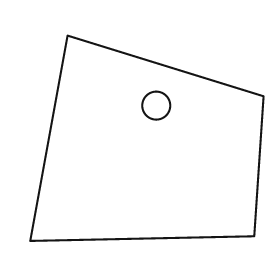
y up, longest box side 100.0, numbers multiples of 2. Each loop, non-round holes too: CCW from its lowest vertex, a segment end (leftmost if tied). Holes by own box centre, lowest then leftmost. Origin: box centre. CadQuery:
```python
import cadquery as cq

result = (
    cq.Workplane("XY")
    .moveTo(-50.0, -44.0)
    .lineTo(46.0, -42.0)
    .lineTo(50.0, 18.0)
    .lineTo(-34.0, 44.0)
    .close()
    .moveTo(4.0, 14.0)
    .circle(6.0)
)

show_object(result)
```